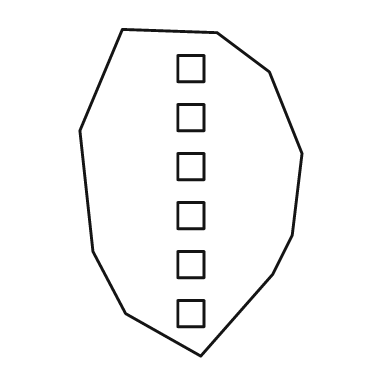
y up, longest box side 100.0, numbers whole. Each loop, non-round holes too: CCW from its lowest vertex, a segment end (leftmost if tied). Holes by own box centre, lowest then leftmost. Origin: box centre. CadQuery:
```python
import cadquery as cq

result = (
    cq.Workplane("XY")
    .moveTo(3.0, -50.0)
    .lineTo(25.0, -25.0)
    .lineTo(31.0, -13.0)
    .lineTo(34.0, 12.0)
    .lineTo(24.0, 37.0)
    .lineTo(8.0, 49.0)
    .lineTo(-21.0, 50.0)
    .lineTo(-34.0, 19.0)
    .lineTo(-30.0, -18.0)
    .lineTo(-20.0, -37.0)
    .close()
    .moveTo(-4.0, -41.0)
    .lineTo(4.0, -41.0)
    .lineTo(4.0, -33.0)
    .lineTo(-4.0, -33.0)
    .close()
    .moveTo(-4.0, -26.0)
    .lineTo(4.0, -26.0)
    .lineTo(4.0, -18.0)
    .lineTo(-4.0, -18.0)
    .close()
    .moveTo(-4.0, -11.0)
    .lineTo(4.0, -11.0)
    .lineTo(4.0, -3.0)
    .lineTo(-4.0, -3.0)
    .close()
    .moveTo(-4.0, 4.0)
    .lineTo(4.0, 4.0)
    .lineTo(4.0, 12.0)
    .lineTo(-4.0, 12.0)
    .close()
    .moveTo(-4.0, 19.0)
    .lineTo(4.0, 19.0)
    .lineTo(4.0, 27.0)
    .lineTo(-4.0, 27.0)
    .close()
    .moveTo(-4.0, 34.0)
    .lineTo(4.0, 34.0)
    .lineTo(4.0, 42.0)
    .lineTo(-4.0, 42.0)
    .close()
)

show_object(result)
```